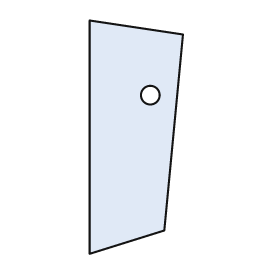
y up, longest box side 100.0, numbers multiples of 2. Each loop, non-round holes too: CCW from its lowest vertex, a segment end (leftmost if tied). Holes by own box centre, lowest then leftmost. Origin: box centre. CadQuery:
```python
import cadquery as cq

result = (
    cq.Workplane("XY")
    .moveTo(-20.0, -50.0)
    .lineTo(12.0, -40.0)
    .lineTo(20.0, 44.0)
    .lineTo(-20.0, 50.0)
    .close()
    .moveTo(6.0, 18.0)
    .circle(4.0)
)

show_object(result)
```